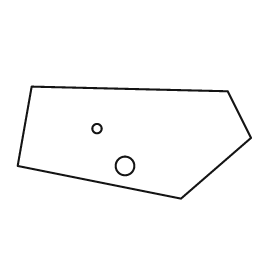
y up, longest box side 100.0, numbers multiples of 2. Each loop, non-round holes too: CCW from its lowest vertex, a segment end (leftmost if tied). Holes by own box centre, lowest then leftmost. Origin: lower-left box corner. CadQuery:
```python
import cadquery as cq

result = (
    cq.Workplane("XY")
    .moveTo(70.0, 0.0)
    .lineTo(100.0, 26.0)
    .lineTo(90.0, 46.0)
    .lineTo(6.0, 48.0)
    .lineTo(0.0, 14.0)
    .close()
    .moveTo(46.0, 14.0)
    .circle(4.0)
    .moveTo(34.0, 30.0)
    .circle(2.0)
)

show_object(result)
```